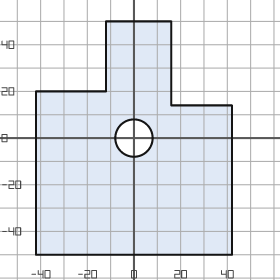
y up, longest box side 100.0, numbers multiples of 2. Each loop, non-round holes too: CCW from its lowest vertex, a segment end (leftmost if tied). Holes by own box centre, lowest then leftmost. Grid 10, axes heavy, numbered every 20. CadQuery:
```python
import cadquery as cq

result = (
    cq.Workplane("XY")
    .moveTo(-42.0, -50.0)
    .lineTo(42.0, -50.0)
    .lineTo(42.0, 14.0)
    .lineTo(16.0, 14.0)
    .lineTo(16.0, 50.0)
    .lineTo(-12.0, 50.0)
    .lineTo(-12.0, 20.0)
    .lineTo(-42.0, 20.0)
    .close()
    .moveTo(0.0, 0.0)
    .circle(8.0)
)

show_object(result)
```